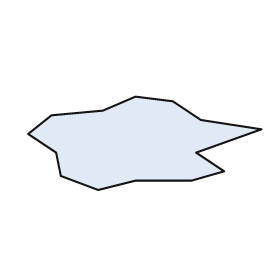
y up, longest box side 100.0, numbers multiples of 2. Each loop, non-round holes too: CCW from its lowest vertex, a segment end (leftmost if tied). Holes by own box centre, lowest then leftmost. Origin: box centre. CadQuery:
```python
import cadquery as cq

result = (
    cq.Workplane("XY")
    .moveTo(-20.0, -20.0)
    .lineTo(-4.0, -16.0)
    .lineTo(20.0, -16.0)
    .lineTo(34.0, -12.0)
    .lineTo(22.0, -4.0)
    .lineTo(50.0, 6.0)
    .lineTo(24.0, 10.0)
    .lineTo(12.0, 18.0)
    .lineTo(-4.0, 20.0)
    .lineTo(-18.0, 14.0)
    .lineTo(-40.0, 12.0)
    .lineTo(-50.0, 4.0)
    .lineTo(-38.0, -4.0)
    .lineTo(-36.0, -14.0)
    .close()
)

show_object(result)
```